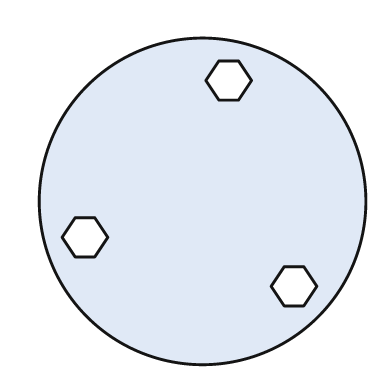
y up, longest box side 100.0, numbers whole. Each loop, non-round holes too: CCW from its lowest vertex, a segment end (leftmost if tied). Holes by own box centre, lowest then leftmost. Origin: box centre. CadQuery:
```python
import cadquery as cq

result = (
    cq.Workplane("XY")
    .moveTo(0.0, 0.0)
    .circle(50.0)
    .moveTo(25.0, -32.0)
    .lineTo(31.0, -32.0)
    .lineTo(35.0, -26.0)
    .lineTo(31.0, -20.0)
    .lineTo(25.0, -20.0)
    .lineTo(21.0, -26.0)
    .close()
    .moveTo(-39.0, -17.0)
    .lineTo(-33.0, -17.0)
    .lineTo(-29.0, -11.0)
    .lineTo(-33.0, -5.0)
    .lineTo(-39.0, -5.0)
    .lineTo(-43.0, -11.0)
    .close()
    .moveTo(5.0, 31.0)
    .lineTo(11.0, 31.0)
    .lineTo(15.0, 37.0)
    .lineTo(11.0, 43.0)
    .lineTo(5.0, 43.0)
    .lineTo(1.0, 37.0)
    .close()
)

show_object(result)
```